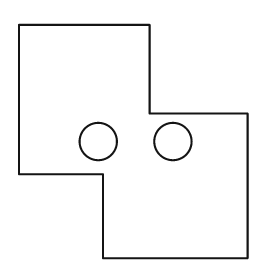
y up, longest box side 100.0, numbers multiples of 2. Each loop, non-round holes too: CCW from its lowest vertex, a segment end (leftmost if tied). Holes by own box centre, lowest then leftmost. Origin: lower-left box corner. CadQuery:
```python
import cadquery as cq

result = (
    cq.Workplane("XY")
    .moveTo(36.0, 0.0)
    .lineTo(98.0, 0.0)
    .lineTo(98.0, 62.0)
    .lineTo(56.0, 62.0)
    .lineTo(56.0, 100.0)
    .lineTo(0.0, 100.0)
    .lineTo(0.0, 36.0)
    .lineTo(36.0, 36.0)
    .close()
    .moveTo(34.0, 50.0)
    .circle(8.0)
    .moveTo(66.0, 50.0)
    .circle(8.0)
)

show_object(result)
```